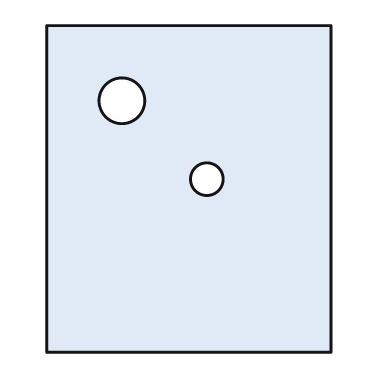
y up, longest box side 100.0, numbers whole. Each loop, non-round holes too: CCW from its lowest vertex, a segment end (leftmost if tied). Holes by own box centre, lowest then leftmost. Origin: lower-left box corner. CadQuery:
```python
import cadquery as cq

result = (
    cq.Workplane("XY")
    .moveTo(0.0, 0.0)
    .lineTo(87.0, 0.0)
    .lineTo(87.0, 100.0)
    .lineTo(0.0, 100.0)
    .close()
    .moveTo(49.0, 53.0)
    .circle(5.0)
    .moveTo(23.0, 77.0)
    .circle(7.0)
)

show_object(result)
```